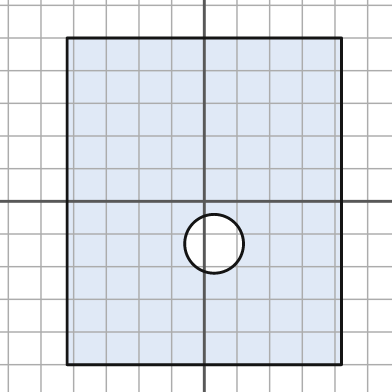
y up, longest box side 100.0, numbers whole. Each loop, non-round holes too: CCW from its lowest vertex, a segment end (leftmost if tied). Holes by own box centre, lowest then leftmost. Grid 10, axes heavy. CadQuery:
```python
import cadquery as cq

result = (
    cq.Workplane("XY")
    .moveTo(-42.0, -50.0)
    .lineTo(42.0, -50.0)
    .lineTo(42.0, 50.0)
    .lineTo(-42.0, 50.0)
    .close()
    .moveTo(3.0, -13.0)
    .circle(9.0)
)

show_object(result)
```